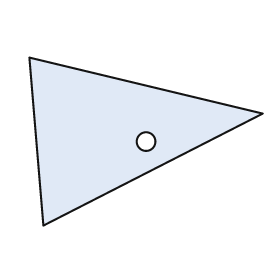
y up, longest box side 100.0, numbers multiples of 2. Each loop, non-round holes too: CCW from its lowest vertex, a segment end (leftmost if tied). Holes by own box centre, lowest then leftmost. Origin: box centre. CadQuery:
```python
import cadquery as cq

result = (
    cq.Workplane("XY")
    .moveTo(-44.0, -36.0)
    .lineTo(50.0, 12.0)
    .lineTo(-50.0, 36.0)
    .close()
    .moveTo(0.0, 0.0)
    .circle(4.0)
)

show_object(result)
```